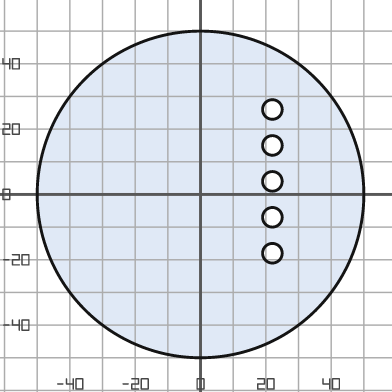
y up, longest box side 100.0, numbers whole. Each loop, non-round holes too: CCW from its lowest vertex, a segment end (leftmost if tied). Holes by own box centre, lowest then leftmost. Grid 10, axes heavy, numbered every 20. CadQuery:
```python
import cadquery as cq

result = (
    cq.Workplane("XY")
    .moveTo(0.0, 0.0)
    .circle(50.0)
    .moveTo(22.0, -18.0)
    .circle(3.0)
    .moveTo(22.0, -7.0)
    .circle(3.0)
    .moveTo(22.0, 4.0)
    .circle(3.0)
    .moveTo(22.0, 15.0)
    .circle(3.0)
    .moveTo(22.0, 26.0)
    .circle(3.0)
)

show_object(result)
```